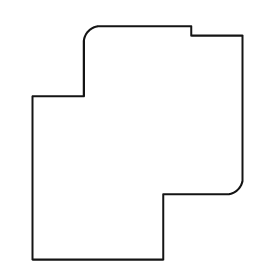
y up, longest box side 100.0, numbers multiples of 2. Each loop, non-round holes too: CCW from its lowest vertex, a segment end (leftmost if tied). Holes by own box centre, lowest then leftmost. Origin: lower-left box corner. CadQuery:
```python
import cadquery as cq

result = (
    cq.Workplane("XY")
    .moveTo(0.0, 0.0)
    .lineTo(56.0, 0.0)
    .lineTo(56.0, 28.0)
    .lineTo(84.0, 28.0)
    .threePointArc((88.0, 30.0), (90.0, 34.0))
    .lineTo(90.0, 96.0)
    .lineTo(68.0, 96.0)
    .lineTo(68.0, 100.0)
    .lineTo(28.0, 100.0)
    .threePointArc((24.0, 98.0), (22.0, 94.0))
    .lineTo(22.0, 70.0)
    .lineTo(0.0, 70.0)
    .close()
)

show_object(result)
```